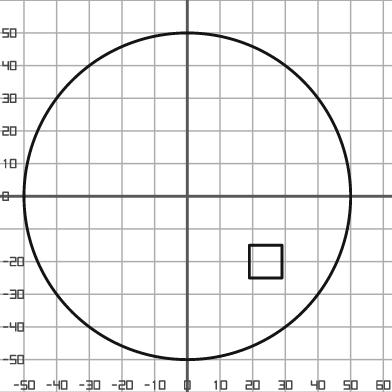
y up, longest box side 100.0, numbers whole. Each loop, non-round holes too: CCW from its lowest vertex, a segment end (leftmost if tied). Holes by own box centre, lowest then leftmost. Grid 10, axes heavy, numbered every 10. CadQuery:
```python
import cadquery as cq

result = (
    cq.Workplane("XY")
    .moveTo(0.0, 0.0)
    .circle(50.0)
    .moveTo(19.0, -25.0)
    .lineTo(29.0, -25.0)
    .lineTo(29.0, -15.0)
    .lineTo(19.0, -15.0)
    .close()
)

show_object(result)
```